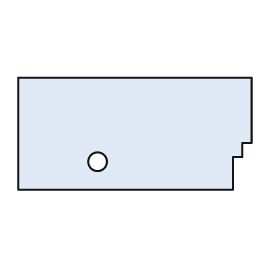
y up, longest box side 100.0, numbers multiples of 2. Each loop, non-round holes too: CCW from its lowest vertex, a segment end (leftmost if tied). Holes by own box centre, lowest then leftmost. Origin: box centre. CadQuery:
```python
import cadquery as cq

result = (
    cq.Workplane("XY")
    .moveTo(-50.0, -24.0)
    .lineTo(42.0, -24.0)
    .lineTo(42.0, -10.0)
    .lineTo(46.0, -10.0)
    .lineTo(46.0, -4.0)
    .lineTo(50.0, -4.0)
    .lineTo(50.0, 24.0)
    .lineTo(-50.0, 24.0)
    .close()
    .moveTo(-16.0, -12.0)
    .circle(4.0)
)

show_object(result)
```